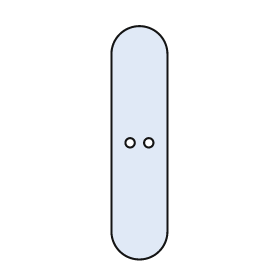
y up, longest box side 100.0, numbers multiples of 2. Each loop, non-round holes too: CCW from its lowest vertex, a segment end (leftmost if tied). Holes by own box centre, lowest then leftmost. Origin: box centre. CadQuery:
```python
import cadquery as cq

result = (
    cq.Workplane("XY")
    .moveTo(-12.0, -38.0)
    .threePointArc((0.0, -50.0), (12.0, -38.0))
    .lineTo(12.0, 38.0)
    .threePointArc((0.0, 50.0), (-12.0, 38.0))
    .close()
    .moveTo(-4.0, 0.0)
    .circle(2.0)
    .moveTo(4.0, 0.0)
    .circle(2.0)
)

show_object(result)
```